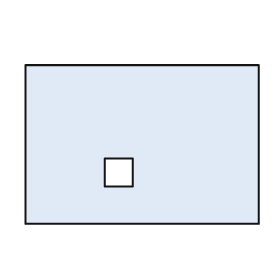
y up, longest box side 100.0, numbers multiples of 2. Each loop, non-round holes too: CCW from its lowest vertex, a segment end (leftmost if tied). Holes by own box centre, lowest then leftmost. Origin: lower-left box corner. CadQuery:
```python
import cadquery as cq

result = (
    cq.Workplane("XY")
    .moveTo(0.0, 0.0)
    .lineTo(100.0, 0.0)
    .lineTo(100.0, 68.0)
    .lineTo(0.0, 68.0)
    .close()
    .moveTo(34.0, 16.0)
    .lineTo(46.0, 16.0)
    .lineTo(46.0, 28.0)
    .lineTo(34.0, 28.0)
    .close()
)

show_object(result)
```